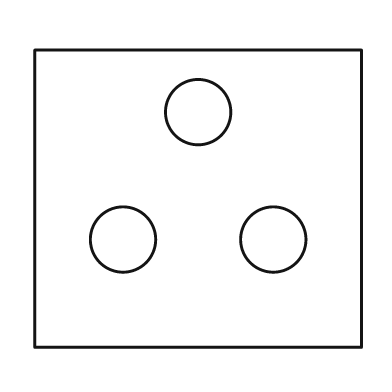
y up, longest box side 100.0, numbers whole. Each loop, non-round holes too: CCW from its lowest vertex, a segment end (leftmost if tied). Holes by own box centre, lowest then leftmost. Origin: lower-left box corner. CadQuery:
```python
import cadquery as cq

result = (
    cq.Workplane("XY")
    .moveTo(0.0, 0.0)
    .lineTo(100.0, 0.0)
    .lineTo(100.0, 91.0)
    .lineTo(0.0, 91.0)
    .close()
    .moveTo(27.0, 33.0)
    .circle(10.0)
    .moveTo(73.0, 33.0)
    .circle(10.0)
    .moveTo(50.0, 72.0)
    .circle(10.0)
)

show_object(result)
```